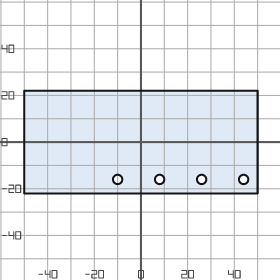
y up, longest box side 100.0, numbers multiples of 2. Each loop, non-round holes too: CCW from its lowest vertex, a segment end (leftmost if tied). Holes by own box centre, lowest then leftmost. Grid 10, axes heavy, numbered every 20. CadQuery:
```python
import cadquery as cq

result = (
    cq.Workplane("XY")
    .moveTo(-50.0, -22.0)
    .lineTo(50.0, -22.0)
    .lineTo(50.0, 22.0)
    .lineTo(-50.0, 22.0)
    .close()
    .moveTo(-10.0, -16.0)
    .circle(2.0)
    .moveTo(8.0, -16.0)
    .circle(2.0)
    .moveTo(26.0, -16.0)
    .circle(2.0)
    .moveTo(44.0, -16.0)
    .circle(2.0)
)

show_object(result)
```